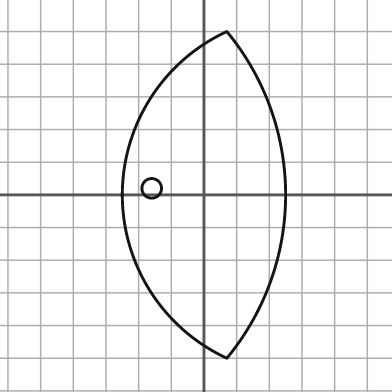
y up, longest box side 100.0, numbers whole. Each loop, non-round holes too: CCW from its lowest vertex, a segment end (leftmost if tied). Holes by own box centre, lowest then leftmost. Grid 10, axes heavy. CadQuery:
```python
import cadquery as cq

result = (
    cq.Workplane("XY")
    .moveTo(7.0, -50.0)
    .threePointArc((25.0, 0.0), (7.0, 50.0))
    .threePointArc((-25.0, 0.0), (7.0, -50.0))
    .close()
    .moveTo(-16.0, 2.0)
    .circle(3.0)
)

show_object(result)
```